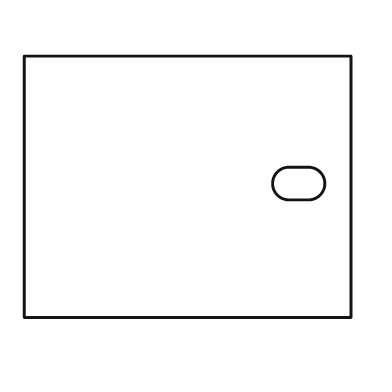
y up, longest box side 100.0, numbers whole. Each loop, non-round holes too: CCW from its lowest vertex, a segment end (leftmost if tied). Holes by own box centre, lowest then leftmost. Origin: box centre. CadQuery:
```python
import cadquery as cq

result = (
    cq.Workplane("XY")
    .moveTo(-50.0, -40.0)
    .lineTo(50.0, -40.0)
    .lineTo(50.0, 40.0)
    .lineTo(-50.0, 40.0)
    .close()
    .moveTo(31.0, -4.0)
    .lineTo(37.0, -4.0)
    .threePointArc((42.0, 1.0), (37.0, 6.0))
    .lineTo(31.0, 6.0)
    .threePointArc((26.0, 1.0), (31.0, -4.0))
    .close()
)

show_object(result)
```